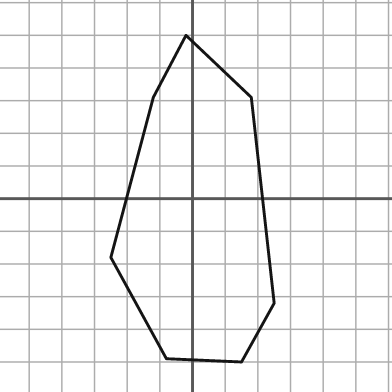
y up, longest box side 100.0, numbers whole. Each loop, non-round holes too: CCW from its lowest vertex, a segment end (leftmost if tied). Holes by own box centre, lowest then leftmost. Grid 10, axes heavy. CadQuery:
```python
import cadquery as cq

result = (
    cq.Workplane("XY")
    .moveTo(15.0, -50.0)
    .lineTo(25.0, -32.0)
    .lineTo(18.0, 31.0)
    .lineTo(-2.0, 50.0)
    .lineTo(-12.0, 31.0)
    .lineTo(-25.0, -18.0)
    .lineTo(-8.0, -49.0)
    .close()
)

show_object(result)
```